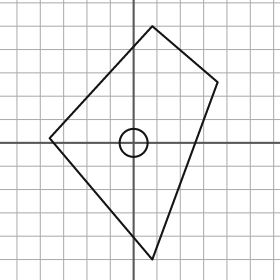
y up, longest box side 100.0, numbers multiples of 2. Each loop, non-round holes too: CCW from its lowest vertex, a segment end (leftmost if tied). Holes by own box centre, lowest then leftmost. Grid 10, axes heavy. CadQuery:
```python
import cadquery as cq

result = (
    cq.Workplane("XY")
    .moveTo(8.0, -50.0)
    .lineTo(36.0, 26.0)
    .lineTo(8.0, 50.0)
    .lineTo(-36.0, 2.0)
    .close()
    .moveTo(0.0, 0.0)
    .circle(6.0)
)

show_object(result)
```